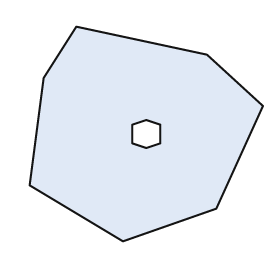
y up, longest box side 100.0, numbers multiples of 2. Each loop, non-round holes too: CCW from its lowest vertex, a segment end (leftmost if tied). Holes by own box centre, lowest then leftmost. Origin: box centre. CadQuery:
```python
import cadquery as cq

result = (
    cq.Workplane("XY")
    .moveTo(-10.0, -46.0)
    .lineTo(30.0, -32.0)
    .lineTo(50.0, 12.0)
    .lineTo(26.0, 34.0)
    .lineTo(-30.0, 46.0)
    .lineTo(-44.0, 24.0)
    .lineTo(-50.0, -22.0)
    .close()
    .moveTo(0.0, -6.0)
    .lineTo(6.0, -4.0)
    .lineTo(6.0, 4.0)
    .lineTo(0.0, 6.0)
    .lineTo(-6.0, 4.0)
    .lineTo(-6.0, -4.0)
    .close()
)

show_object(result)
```